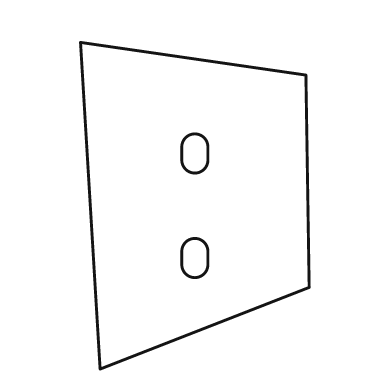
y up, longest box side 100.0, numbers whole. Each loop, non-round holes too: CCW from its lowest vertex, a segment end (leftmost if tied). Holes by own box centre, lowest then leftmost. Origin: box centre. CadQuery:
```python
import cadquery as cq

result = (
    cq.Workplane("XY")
    .moveTo(-29.0, -50.0)
    .lineTo(35.0, -25.0)
    .lineTo(34.0, 40.0)
    .lineTo(-35.0, 50.0)
    .close()
    .moveTo(-4.0, -18.0)
    .threePointArc((0.0, -22.0), (4.0, -18.0))
    .lineTo(4.0, -14.0)
    .threePointArc((0.0, -10.0), (-4.0, -14.0))
    .close()
    .moveTo(-4.0, 14.0)
    .threePointArc((0.0, 10.0), (4.0, 14.0))
    .lineTo(4.0, 18.0)
    .threePointArc((0.0, 22.0), (-4.0, 18.0))
    .close()
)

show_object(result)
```